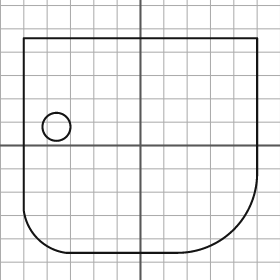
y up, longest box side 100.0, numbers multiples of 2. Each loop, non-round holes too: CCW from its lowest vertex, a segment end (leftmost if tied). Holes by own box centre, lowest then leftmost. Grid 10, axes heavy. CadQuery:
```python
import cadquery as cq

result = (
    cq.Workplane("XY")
    .moveTo(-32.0, -46.0)
    .lineTo(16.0, -46.0)
    .threePointArc((40.0, -36.0), (50.0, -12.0))
    .lineTo(50.0, 46.0)
    .lineTo(-50.0, 46.0)
    .lineTo(-50.0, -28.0)
    .threePointArc((-44.0, -40.0), (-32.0, -46.0))
    .close()
    .moveTo(-36.0, 8.0)
    .circle(6.0)
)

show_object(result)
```